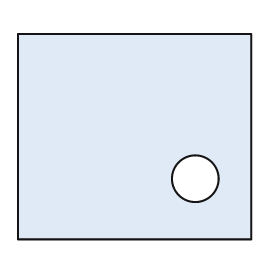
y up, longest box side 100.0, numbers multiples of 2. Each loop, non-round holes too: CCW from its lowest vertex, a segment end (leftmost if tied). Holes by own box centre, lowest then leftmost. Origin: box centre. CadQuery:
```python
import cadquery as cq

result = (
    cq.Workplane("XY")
    .moveTo(-50.0, -44.0)
    .lineTo(50.0, -44.0)
    .lineTo(50.0, 44.0)
    .lineTo(-50.0, 44.0)
    .close()
    .moveTo(26.0, -18.0)
    .circle(10.0)
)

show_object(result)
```